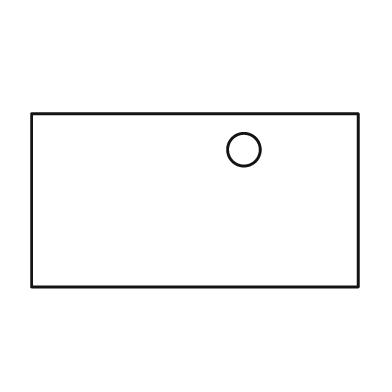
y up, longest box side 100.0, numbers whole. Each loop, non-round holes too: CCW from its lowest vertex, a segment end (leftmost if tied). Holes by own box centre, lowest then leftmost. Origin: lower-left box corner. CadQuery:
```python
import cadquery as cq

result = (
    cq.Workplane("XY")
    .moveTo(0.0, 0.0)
    .lineTo(100.0, 0.0)
    .lineTo(100.0, 53.0)
    .lineTo(0.0, 53.0)
    .close()
    .moveTo(65.0, 42.0)
    .circle(5.0)
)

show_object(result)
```